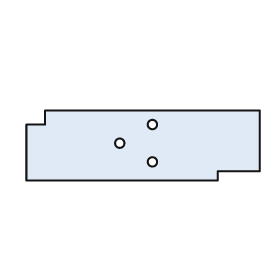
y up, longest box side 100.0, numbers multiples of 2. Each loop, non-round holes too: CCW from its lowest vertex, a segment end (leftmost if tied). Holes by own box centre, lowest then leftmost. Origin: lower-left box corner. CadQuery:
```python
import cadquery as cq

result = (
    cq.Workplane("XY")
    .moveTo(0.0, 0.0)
    .lineTo(82.0, 0.0)
    .lineTo(82.0, 4.0)
    .lineTo(100.0, 4.0)
    .lineTo(100.0, 30.0)
    .lineTo(8.0, 30.0)
    .lineTo(8.0, 24.0)
    .lineTo(0.0, 24.0)
    .close()
    .moveTo(54.0, 8.0)
    .circle(2.0)
    .moveTo(40.0, 16.0)
    .circle(2.0)
    .moveTo(54.0, 24.0)
    .circle(2.0)
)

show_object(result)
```